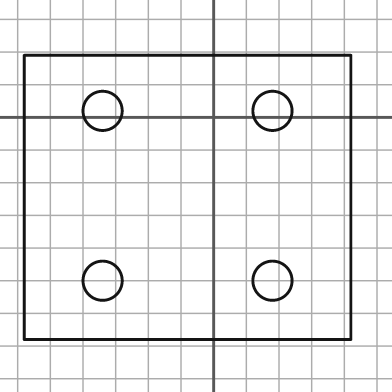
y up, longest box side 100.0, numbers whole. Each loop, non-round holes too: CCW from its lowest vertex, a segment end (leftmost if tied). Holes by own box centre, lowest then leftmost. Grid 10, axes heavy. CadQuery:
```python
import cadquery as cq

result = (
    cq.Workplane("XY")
    .moveTo(-58.0, -68.0)
    .lineTo(42.0, -68.0)
    .lineTo(42.0, 19.0)
    .lineTo(-58.0, 19.0)
    .close()
    .moveTo(-34.0, -50.0)
    .circle(6.0)
    .moveTo(18.0, -50.0)
    .circle(6.0)
    .moveTo(-34.0, 2.0)
    .circle(6.0)
    .moveTo(18.0, 2.0)
    .circle(6.0)
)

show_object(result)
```